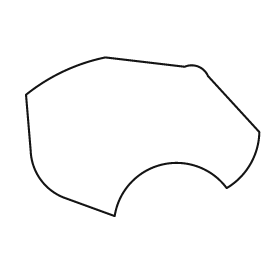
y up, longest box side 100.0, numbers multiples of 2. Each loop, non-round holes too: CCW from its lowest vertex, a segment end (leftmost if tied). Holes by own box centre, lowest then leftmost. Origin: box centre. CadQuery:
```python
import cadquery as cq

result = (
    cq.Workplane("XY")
    .moveTo(-12.0, -34.0)
    .threePointArc((8.0, -12.0), (36.0, -22.0))
    .threePointArc((46.0, -12.0), (50.0, 2.0))
    .lineTo(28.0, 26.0)
    .threePointArc((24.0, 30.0), (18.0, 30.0))
    .lineTo(-16.0, 34.0)
    .threePointArc((-34.0, 28.0), (-50.0, 18.0))
    .lineTo(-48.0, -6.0)
    .threePointArc((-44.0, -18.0), (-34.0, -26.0))
    .close()
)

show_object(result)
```